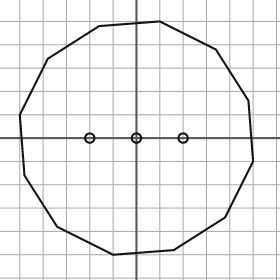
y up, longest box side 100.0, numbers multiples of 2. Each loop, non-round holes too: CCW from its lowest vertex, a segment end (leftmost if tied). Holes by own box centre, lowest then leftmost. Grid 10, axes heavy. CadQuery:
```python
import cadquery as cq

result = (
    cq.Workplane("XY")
    .moveTo(-10.0, -50.0)
    .lineTo(16.0, -48.0)
    .lineTo(38.0, -34.0)
    .lineTo(50.0, -10.0)
    .lineTo(48.0, 16.0)
    .lineTo(34.0, 38.0)
    .lineTo(10.0, 50.0)
    .lineTo(-16.0, 48.0)
    .lineTo(-38.0, 34.0)
    .lineTo(-50.0, 10.0)
    .lineTo(-48.0, -16.0)
    .lineTo(-34.0, -38.0)
    .close()
    .moveTo(-20.0, 0.0)
    .circle(2.0)
    .moveTo(0.0, 0.0)
    .circle(2.0)
    .moveTo(20.0, 0.0)
    .circle(2.0)
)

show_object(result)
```